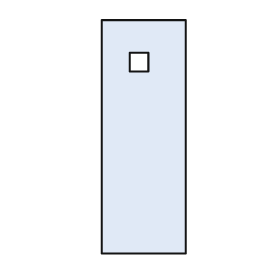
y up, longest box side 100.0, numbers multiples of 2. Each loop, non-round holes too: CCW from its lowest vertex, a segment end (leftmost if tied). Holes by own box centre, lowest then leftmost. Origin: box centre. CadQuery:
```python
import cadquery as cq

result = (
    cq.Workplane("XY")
    .moveTo(-18.0, -50.0)
    .lineTo(18.0, -50.0)
    .lineTo(18.0, 50.0)
    .lineTo(-18.0, 50.0)
    .close()
    .moveTo(-6.0, 28.0)
    .lineTo(2.0, 28.0)
    .lineTo(2.0, 36.0)
    .lineTo(-6.0, 36.0)
    .close()
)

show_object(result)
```